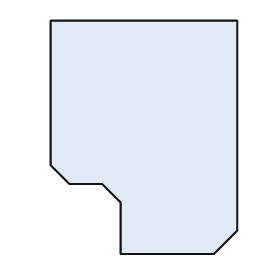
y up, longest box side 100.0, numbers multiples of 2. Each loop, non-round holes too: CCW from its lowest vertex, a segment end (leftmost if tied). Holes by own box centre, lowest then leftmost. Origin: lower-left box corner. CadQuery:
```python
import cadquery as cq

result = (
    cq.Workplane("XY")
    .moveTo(30.0, 0.0)
    .lineTo(70.0, 0.0)
    .lineTo(80.0, 10.0)
    .lineTo(80.0, 100.0)
    .lineTo(0.0, 100.0)
    .lineTo(0.0, 38.0)
    .lineTo(8.0, 30.0)
    .lineTo(22.0, 30.0)
    .lineTo(30.0, 22.0)
    .close()
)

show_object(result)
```